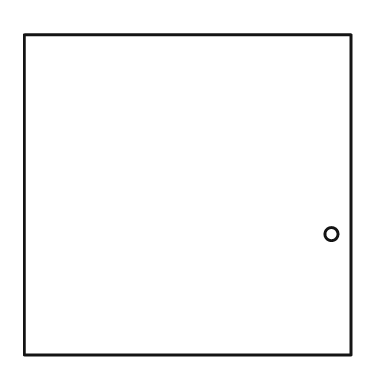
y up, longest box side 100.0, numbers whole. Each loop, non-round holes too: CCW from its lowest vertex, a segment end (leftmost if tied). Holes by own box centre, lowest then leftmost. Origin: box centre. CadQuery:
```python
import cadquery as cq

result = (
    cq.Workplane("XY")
    .moveTo(-50.0, -49.0)
    .lineTo(50.0, -49.0)
    .lineTo(50.0, 49.0)
    .lineTo(-50.0, 49.0)
    .close()
    .moveTo(44.0, -12.0)
    .circle(2.0)
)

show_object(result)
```